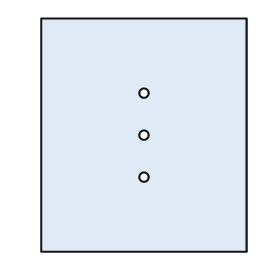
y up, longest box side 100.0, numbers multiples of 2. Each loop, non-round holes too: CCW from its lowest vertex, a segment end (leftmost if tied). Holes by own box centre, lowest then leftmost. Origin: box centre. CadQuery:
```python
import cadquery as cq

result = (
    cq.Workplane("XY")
    .moveTo(-44.0, -50.0)
    .lineTo(44.0, -50.0)
    .lineTo(44.0, 50.0)
    .lineTo(-44.0, 50.0)
    .close()
    .moveTo(0.0, -18.0)
    .circle(2.0)
    .moveTo(0.0, 0.0)
    .circle(2.0)
    .moveTo(0.0, 18.0)
    .circle(2.0)
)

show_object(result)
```